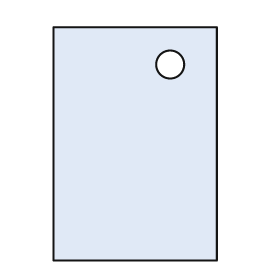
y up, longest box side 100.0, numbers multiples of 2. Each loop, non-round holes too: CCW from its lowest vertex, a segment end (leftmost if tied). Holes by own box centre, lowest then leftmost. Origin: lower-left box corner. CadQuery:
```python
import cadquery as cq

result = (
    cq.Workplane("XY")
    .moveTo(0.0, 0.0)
    .lineTo(70.0, 0.0)
    .lineTo(70.0, 100.0)
    .lineTo(0.0, 100.0)
    .close()
    .moveTo(50.0, 84.0)
    .circle(6.0)
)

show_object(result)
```